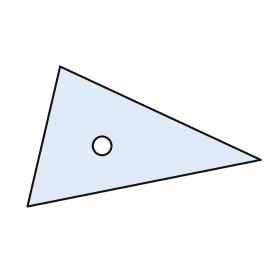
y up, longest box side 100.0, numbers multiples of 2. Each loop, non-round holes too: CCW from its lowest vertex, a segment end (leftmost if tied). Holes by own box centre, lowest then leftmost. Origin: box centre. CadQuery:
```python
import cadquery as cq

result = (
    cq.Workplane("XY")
    .moveTo(-50.0, -30.0)
    .lineTo(50.0, -10.0)
    .lineTo(-36.0, 30.0)
    .close()
    .moveTo(-18.0, -4.0)
    .circle(4.0)
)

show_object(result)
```